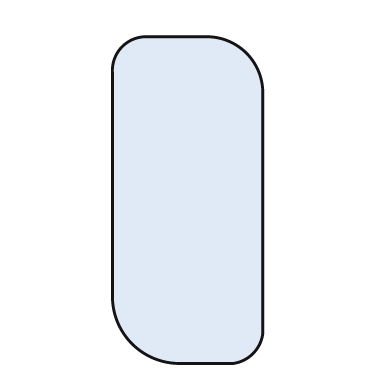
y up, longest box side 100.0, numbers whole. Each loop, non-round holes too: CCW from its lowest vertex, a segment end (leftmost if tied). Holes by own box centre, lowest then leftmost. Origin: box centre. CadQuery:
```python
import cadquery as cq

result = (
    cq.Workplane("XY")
    .moveTo(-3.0, -50.0)
    .lineTo(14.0, -50.0)
    .threePointArc((20.0, -47.0), (23.0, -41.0))
    .lineTo(23.0, 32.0)
    .threePointArc((18.0, 45.0), (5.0, 50.0))
    .lineTo(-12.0, 50.0)
    .threePointArc((-20.0, 47.0), (-23.0, 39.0))
    .lineTo(-23.0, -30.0)
    .threePointArc((-17.0, -44.0), (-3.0, -50.0))
    .close()
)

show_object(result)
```